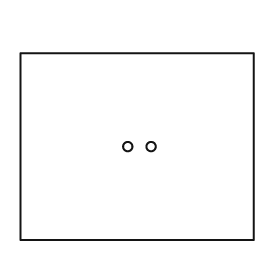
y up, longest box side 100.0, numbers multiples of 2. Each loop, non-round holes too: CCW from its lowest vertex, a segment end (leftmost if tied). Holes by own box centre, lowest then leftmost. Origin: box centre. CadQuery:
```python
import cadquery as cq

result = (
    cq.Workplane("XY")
    .moveTo(-50.0, -40.0)
    .lineTo(50.0, -40.0)
    .lineTo(50.0, 40.0)
    .lineTo(-50.0, 40.0)
    .close()
    .moveTo(-4.0, 0.0)
    .circle(2.0)
    .moveTo(6.0, 0.0)
    .circle(2.0)
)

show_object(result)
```